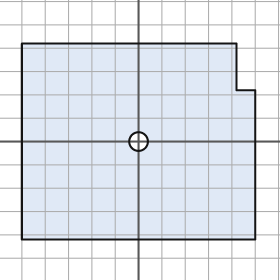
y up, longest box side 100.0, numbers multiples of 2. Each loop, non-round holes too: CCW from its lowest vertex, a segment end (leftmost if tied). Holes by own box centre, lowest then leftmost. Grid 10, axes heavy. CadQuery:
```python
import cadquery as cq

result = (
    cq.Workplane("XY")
    .moveTo(-50.0, -42.0)
    .lineTo(50.0, -42.0)
    .lineTo(50.0, 22.0)
    .lineTo(42.0, 22.0)
    .lineTo(42.0, 42.0)
    .lineTo(-50.0, 42.0)
    .close()
    .moveTo(0.0, 0.0)
    .circle(4.0)
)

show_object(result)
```